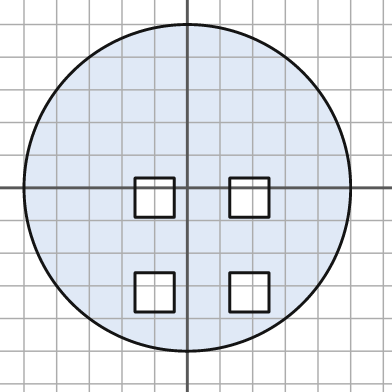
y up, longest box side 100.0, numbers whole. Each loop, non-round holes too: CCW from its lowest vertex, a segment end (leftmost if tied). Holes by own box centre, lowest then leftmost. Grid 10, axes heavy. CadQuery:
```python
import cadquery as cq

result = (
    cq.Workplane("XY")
    .moveTo(0.0, 0.0)
    .circle(50.0)
    .moveTo(-16.0, -38.0)
    .lineTo(-4.0, -38.0)
    .lineTo(-4.0, -26.0)
    .lineTo(-16.0, -26.0)
    .close()
    .moveTo(13.0, -38.0)
    .lineTo(25.0, -38.0)
    .lineTo(25.0, -26.0)
    .lineTo(13.0, -26.0)
    .close()
    .moveTo(-16.0, -9.0)
    .lineTo(-4.0, -9.0)
    .lineTo(-4.0, 3.0)
    .lineTo(-16.0, 3.0)
    .close()
    .moveTo(13.0, -9.0)
    .lineTo(25.0, -9.0)
    .lineTo(25.0, 3.0)
    .lineTo(13.0, 3.0)
    .close()
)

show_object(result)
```